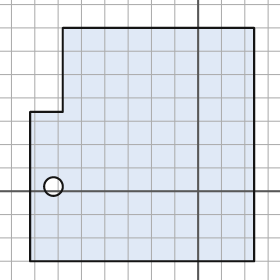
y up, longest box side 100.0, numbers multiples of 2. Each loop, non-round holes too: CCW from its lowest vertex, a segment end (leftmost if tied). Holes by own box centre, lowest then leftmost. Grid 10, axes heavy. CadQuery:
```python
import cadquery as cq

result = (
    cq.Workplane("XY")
    .moveTo(-72.0, -30.0)
    .lineTo(24.0, -30.0)
    .lineTo(24.0, 70.0)
    .lineTo(-58.0, 70.0)
    .lineTo(-58.0, 34.0)
    .lineTo(-72.0, 34.0)
    .close()
    .moveTo(-62.0, 2.0)
    .circle(4.0)
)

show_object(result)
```